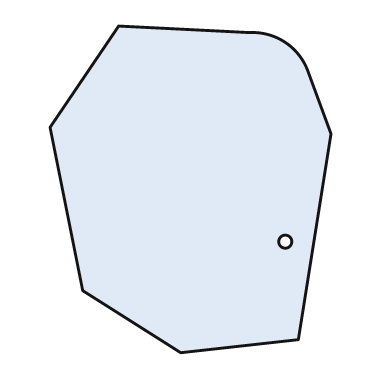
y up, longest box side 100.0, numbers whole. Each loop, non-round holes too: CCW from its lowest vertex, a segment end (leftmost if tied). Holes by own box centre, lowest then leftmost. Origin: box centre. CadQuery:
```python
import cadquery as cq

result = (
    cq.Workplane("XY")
    .moveTo(-3.0, -50.0)
    .lineTo(33.0, -46.0)
    .lineTo(43.0, 17.0)
    .lineTo(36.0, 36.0)
    .threePointArc((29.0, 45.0), (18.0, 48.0))
    .lineTo(-22.0, 50.0)
    .lineTo(-43.0, 19.0)
    .lineTo(-33.0, -31.0)
    .close()
    .moveTo(29.0, -16.0)
    .circle(2.0)
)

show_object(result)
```